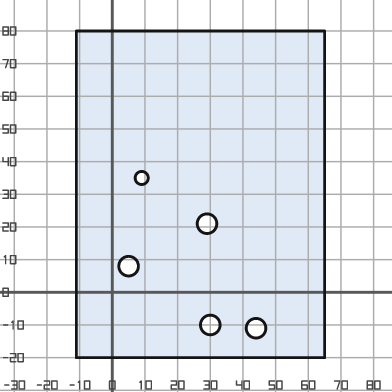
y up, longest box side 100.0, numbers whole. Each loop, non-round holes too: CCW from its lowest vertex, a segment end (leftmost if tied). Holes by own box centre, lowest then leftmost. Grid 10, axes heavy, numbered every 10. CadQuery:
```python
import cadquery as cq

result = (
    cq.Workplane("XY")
    .moveTo(-11.0, -20.0)
    .lineTo(65.0, -20.0)
    .lineTo(65.0, 80.0)
    .lineTo(-11.0, 80.0)
    .close()
    .moveTo(44.0, -11.0)
    .circle(3.0)
    .moveTo(30.0, -10.0)
    .circle(3.0)
    .moveTo(5.0, 8.0)
    .circle(3.0)
    .moveTo(29.0, 21.0)
    .circle(3.0)
    .moveTo(9.0, 35.0)
    .circle(2.0)
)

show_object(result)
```